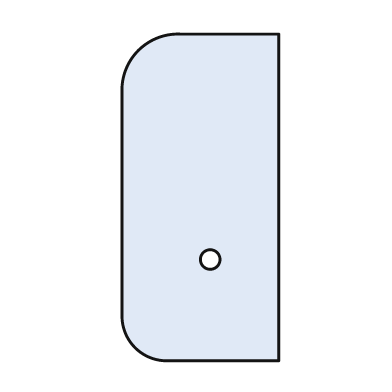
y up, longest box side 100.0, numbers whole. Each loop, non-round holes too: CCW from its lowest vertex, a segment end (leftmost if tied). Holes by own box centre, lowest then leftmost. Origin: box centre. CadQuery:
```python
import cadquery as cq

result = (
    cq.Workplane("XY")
    .moveTo(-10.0, -50.0)
    .lineTo(24.0, -50.0)
    .lineTo(24.0, 50.0)
    .lineTo(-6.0, 50.0)
    .threePointArc((-19.0, 45.0), (-24.0, 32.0))
    .lineTo(-24.0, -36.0)
    .threePointArc((-20.0, -46.0), (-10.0, -50.0))
    .close()
    .moveTo(3.0, -19.0)
    .circle(3.0)
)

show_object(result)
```